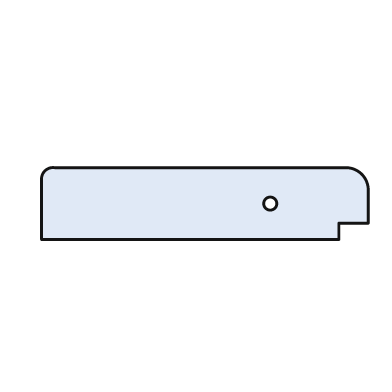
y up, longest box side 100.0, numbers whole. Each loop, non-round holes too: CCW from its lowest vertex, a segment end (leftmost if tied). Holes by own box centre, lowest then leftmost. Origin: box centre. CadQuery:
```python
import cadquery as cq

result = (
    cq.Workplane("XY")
    .moveTo(-50.0, -11.0)
    .lineTo(41.0, -11.0)
    .lineTo(41.0, -6.0)
    .lineTo(50.0, -6.0)
    .lineTo(50.0, 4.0)
    .threePointArc((48.0, 9.0), (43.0, 11.0))
    .lineTo(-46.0, 11.0)
    .threePointArc((-49.0, 10.0), (-50.0, 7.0))
    .close()
    .moveTo(20.0, 0.0)
    .circle(2.0)
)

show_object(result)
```